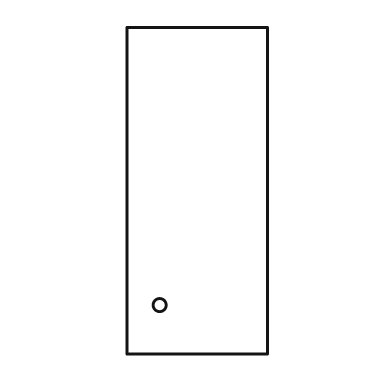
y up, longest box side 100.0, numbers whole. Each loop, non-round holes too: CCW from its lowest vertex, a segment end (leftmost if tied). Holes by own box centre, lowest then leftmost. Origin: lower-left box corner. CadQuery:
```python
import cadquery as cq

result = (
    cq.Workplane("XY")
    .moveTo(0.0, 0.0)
    .lineTo(43.0, 0.0)
    .lineTo(43.0, 100.0)
    .lineTo(0.0, 100.0)
    .close()
    .moveTo(10.0, 15.0)
    .circle(2.0)
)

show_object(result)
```